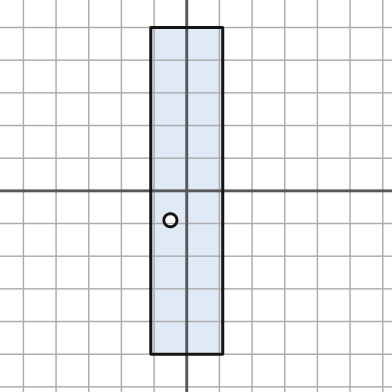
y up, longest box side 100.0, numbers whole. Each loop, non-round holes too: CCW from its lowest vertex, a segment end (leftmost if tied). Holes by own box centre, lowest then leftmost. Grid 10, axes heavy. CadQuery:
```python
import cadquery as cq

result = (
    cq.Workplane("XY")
    .moveTo(-11.0, -50.0)
    .lineTo(11.0, -50.0)
    .lineTo(11.0, 50.0)
    .lineTo(-11.0, 50.0)
    .close()
    .moveTo(-5.0, -9.0)
    .circle(2.0)
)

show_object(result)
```